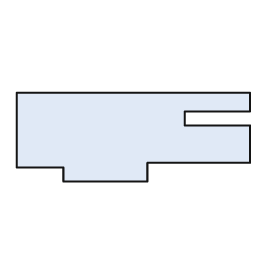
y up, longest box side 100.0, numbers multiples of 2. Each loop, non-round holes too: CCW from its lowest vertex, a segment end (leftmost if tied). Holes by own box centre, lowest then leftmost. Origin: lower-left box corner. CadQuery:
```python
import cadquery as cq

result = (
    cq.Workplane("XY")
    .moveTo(20.0, 0.0)
    .lineTo(56.0, 0.0)
    .lineTo(56.0, 8.0)
    .lineTo(100.0, 8.0)
    .lineTo(100.0, 24.0)
    .lineTo(72.0, 24.0)
    .lineTo(72.0, 30.0)
    .lineTo(100.0, 30.0)
    .lineTo(100.0, 38.0)
    .lineTo(0.0, 38.0)
    .lineTo(0.0, 6.0)
    .lineTo(20.0, 6.0)
    .close()
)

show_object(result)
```